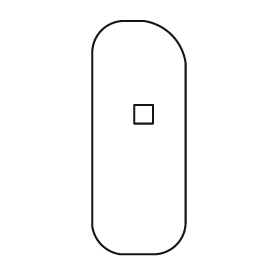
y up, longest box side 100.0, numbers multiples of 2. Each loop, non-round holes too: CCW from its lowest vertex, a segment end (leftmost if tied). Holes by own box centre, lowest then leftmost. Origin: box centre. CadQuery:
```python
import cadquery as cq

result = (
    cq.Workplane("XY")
    .moveTo(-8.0, -50.0)
    .lineTo(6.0, -50.0)
    .threePointArc((16.0, -46.0), (20.0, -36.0))
    .lineTo(20.0, 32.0)
    .threePointArc((14.0, 44.0), (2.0, 50.0))
    .lineTo(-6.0, 50.0)
    .threePointArc((-16.0, 46.0), (-20.0, 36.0))
    .lineTo(-20.0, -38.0)
    .threePointArc((-16.0, -46.0), (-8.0, -50.0))
    .close()
    .moveTo(-2.0, 6.0)
    .lineTo(6.0, 6.0)
    .lineTo(6.0, 14.0)
    .lineTo(-2.0, 14.0)
    .close()
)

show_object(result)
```